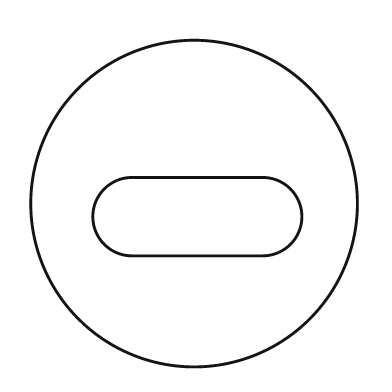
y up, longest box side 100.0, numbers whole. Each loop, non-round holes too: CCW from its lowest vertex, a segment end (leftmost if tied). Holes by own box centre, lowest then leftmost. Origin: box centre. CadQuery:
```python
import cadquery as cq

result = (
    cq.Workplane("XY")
    .moveTo(0.0, 0.0)
    .circle(50.0)
    .moveTo(-19.0, -16.0)
    .lineTo(21.0, -16.0)
    .threePointArc((33.0, -4.0), (21.0, 8.0))
    .lineTo(-19.0, 8.0)
    .threePointArc((-31.0, -4.0), (-19.0, -16.0))
    .close()
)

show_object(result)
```